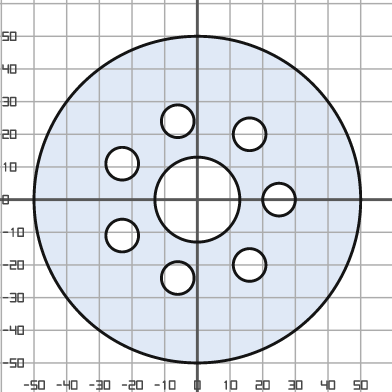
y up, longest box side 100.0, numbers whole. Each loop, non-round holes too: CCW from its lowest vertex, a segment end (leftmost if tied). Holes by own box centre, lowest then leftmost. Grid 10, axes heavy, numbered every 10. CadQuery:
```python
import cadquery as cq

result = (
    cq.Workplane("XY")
    .moveTo(0.0, 0.0)
    .circle(50.0)
    .moveTo(-6.0, -24.0)
    .circle(5.0)
    .moveTo(16.0, -20.0)
    .circle(5.0)
    .moveTo(-23.0, -11.0)
    .circle(5.0)
    .moveTo(0.0, 0.0)
    .circle(13.0)
    .moveTo(25.0, 0.0)
    .circle(5.0)
    .moveTo(-23.0, 11.0)
    .circle(5.0)
    .moveTo(16.0, 20.0)
    .circle(5.0)
    .moveTo(-6.0, 24.0)
    .circle(5.0)
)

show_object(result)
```